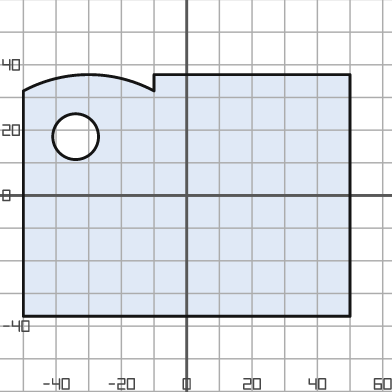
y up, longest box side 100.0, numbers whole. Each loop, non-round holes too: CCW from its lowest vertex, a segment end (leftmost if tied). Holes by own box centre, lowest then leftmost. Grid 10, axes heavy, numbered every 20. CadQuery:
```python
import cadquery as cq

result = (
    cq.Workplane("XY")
    .moveTo(-50.0, -37.0)
    .lineTo(50.0, -37.0)
    .lineTo(50.0, 37.0)
    .lineTo(-10.0, 37.0)
    .lineTo(-10.0, 32.0)
    .threePointArc((-30.0, 37.0), (-50.0, 32.0))
    .close()
    .moveTo(-34.0, 18.0)
    .circle(7.0)
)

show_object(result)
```